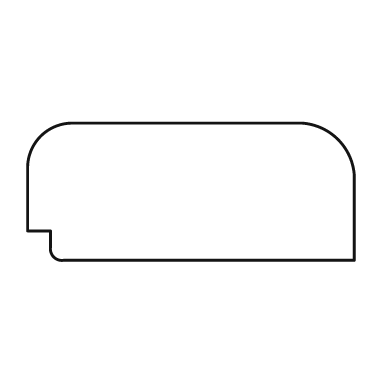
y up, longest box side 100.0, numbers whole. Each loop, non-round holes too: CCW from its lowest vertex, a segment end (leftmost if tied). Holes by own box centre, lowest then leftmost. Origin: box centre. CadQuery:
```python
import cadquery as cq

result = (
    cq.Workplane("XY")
    .moveTo(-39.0, -21.0)
    .lineTo(50.0, -21.0)
    .lineTo(50.0, 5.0)
    .threePointArc((45.0, 16.0), (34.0, 21.0))
    .lineTo(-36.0, 21.0)
    .threePointArc((-46.0, 17.0), (-50.0, 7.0))
    .lineTo(-50.0, -12.0)
    .lineTo(-43.0, -12.0)
    .lineTo(-43.0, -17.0)
    .threePointArc((-42.0, -20.0), (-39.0, -21.0))
    .close()
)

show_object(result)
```